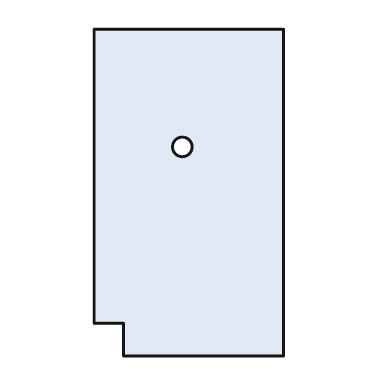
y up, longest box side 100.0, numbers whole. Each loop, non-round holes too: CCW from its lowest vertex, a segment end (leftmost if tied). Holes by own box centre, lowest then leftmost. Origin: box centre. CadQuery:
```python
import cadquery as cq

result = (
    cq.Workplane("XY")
    .moveTo(-20.0, -50.0)
    .lineTo(29.0, -50.0)
    .lineTo(29.0, 50.0)
    .lineTo(-29.0, 50.0)
    .lineTo(-29.0, -40.0)
    .lineTo(-20.0, -40.0)
    .close()
    .moveTo(-2.0, 14.0)
    .circle(3.0)
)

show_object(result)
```